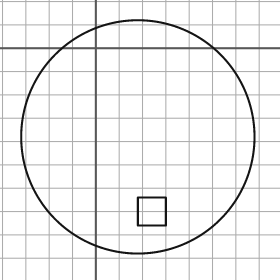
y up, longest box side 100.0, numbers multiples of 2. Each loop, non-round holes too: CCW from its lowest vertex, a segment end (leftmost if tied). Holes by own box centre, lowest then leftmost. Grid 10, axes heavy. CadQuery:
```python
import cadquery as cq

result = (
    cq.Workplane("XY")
    .moveTo(18.0, -38.0)
    .circle(50.0)
    .moveTo(18.0, -76.0)
    .lineTo(30.0, -76.0)
    .lineTo(30.0, -64.0)
    .lineTo(18.0, -64.0)
    .close()
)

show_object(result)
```